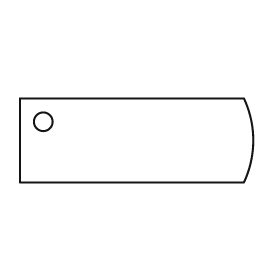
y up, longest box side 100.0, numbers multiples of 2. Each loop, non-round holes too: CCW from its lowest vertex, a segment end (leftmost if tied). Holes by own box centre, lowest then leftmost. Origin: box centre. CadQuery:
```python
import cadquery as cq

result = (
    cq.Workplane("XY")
    .moveTo(-50.0, -18.0)
    .lineTo(46.0, -18.0)
    .threePointArc((50.0, 0.0), (46.0, 18.0))
    .lineTo(-50.0, 18.0)
    .close()
    .moveTo(-40.0, 8.0)
    .circle(4.0)
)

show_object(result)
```